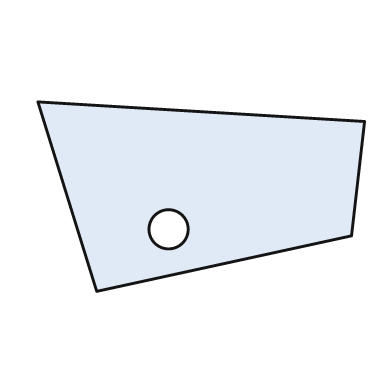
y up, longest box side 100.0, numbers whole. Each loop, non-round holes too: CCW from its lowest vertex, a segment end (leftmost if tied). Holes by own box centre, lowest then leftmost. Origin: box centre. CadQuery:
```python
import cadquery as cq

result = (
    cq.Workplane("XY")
    .moveTo(-32.0, -29.0)
    .lineTo(46.0, -12.0)
    .lineTo(50.0, 23.0)
    .lineTo(-50.0, 29.0)
    .close()
    .moveTo(-10.0, -10.0)
    .circle(6.0)
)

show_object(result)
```